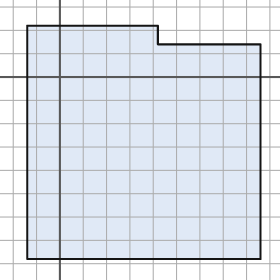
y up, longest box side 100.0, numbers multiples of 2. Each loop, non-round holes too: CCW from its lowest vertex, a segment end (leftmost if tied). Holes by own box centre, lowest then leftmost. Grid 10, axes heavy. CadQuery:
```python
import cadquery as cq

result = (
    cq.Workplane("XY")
    .moveTo(-14.0, -78.0)
    .lineTo(86.0, -78.0)
    .lineTo(86.0, 14.0)
    .lineTo(42.0, 14.0)
    .lineTo(42.0, 22.0)
    .lineTo(-14.0, 22.0)
    .close()
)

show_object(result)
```